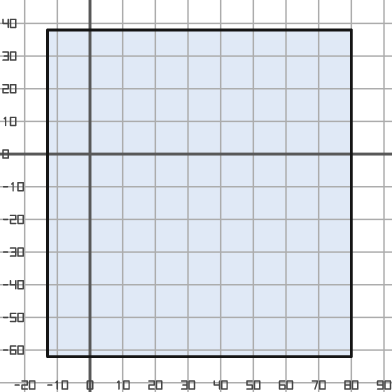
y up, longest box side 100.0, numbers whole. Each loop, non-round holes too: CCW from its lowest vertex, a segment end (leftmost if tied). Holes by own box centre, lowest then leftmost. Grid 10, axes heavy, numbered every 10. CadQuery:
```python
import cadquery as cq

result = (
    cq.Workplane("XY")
    .moveTo(-13.0, -62.0)
    .lineTo(80.0, -62.0)
    .lineTo(80.0, 38.0)
    .lineTo(-13.0, 38.0)
    .close()
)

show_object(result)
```